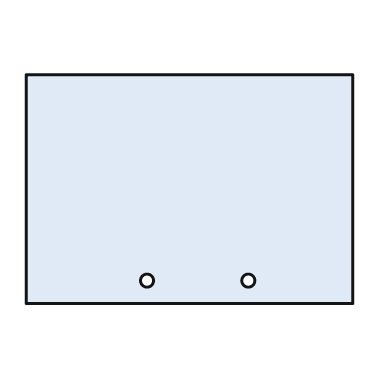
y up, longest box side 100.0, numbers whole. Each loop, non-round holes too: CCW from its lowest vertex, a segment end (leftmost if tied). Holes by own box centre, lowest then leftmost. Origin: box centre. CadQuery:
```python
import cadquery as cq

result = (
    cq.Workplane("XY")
    .moveTo(-50.0, -35.0)
    .lineTo(50.0, -35.0)
    .lineTo(50.0, 35.0)
    .lineTo(-50.0, 35.0)
    .close()
    .moveTo(-13.0, -28.0)
    .circle(2.0)
    .moveTo(18.0, -28.0)
    .circle(2.0)
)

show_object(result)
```